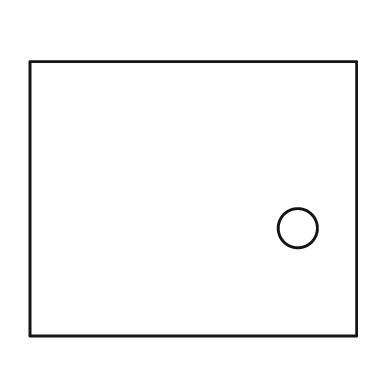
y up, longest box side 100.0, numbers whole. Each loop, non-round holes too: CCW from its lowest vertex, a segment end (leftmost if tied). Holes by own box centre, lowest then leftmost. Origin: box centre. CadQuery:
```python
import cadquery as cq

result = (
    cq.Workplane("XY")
    .moveTo(-50.0, -42.0)
    .lineTo(50.0, -42.0)
    .lineTo(50.0, 42.0)
    .lineTo(-50.0, 42.0)
    .close()
    .moveTo(32.0, -9.0)
    .circle(6.0)
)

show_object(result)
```